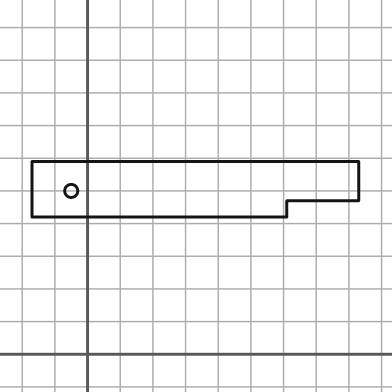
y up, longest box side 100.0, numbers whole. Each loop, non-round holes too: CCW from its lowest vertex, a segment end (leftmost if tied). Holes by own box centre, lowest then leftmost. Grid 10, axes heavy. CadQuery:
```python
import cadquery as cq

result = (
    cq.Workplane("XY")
    .moveTo(-17.0, 42.0)
    .lineTo(61.0, 42.0)
    .lineTo(61.0, 47.0)
    .lineTo(83.0, 47.0)
    .lineTo(83.0, 59.0)
    .lineTo(-17.0, 59.0)
    .close()
    .moveTo(-5.0, 50.0)
    .circle(2.0)
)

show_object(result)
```